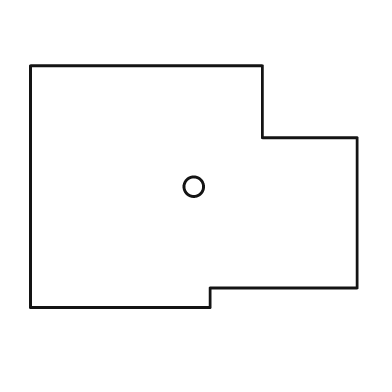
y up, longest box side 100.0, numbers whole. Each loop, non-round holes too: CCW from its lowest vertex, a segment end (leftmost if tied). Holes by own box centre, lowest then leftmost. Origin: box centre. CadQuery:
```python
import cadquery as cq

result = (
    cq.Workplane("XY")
    .moveTo(-50.0, -37.0)
    .lineTo(5.0, -37.0)
    .lineTo(5.0, -31.0)
    .lineTo(50.0, -31.0)
    .lineTo(50.0, 15.0)
    .lineTo(21.0, 15.0)
    .lineTo(21.0, 37.0)
    .lineTo(-50.0, 37.0)
    .close()
    .moveTo(0.0, 0.0)
    .circle(3.0)
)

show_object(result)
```